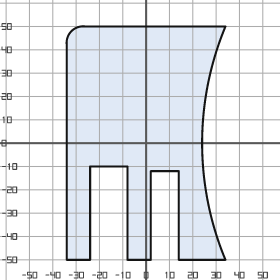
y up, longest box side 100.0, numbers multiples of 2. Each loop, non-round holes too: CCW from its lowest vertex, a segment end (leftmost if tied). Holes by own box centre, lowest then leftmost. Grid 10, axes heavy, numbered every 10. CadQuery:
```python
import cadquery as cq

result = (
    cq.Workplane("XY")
    .moveTo(-34.0, -50.0)
    .lineTo(-24.0, -50.0)
    .lineTo(-24.0, -10.0)
    .lineTo(-8.0, -10.0)
    .lineTo(-8.0, -50.0)
    .lineTo(2.0, -50.0)
    .lineTo(2.0, -12.0)
    .lineTo(14.0, -12.0)
    .lineTo(14.0, -50.0)
    .lineTo(34.0, -50.0)
    .threePointArc((24.0, 0.0), (34.0, 50.0))
    .lineTo(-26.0, 50.0)
    .threePointArc((-32.0, 48.0), (-34.0, 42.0))
    .close()
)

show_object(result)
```